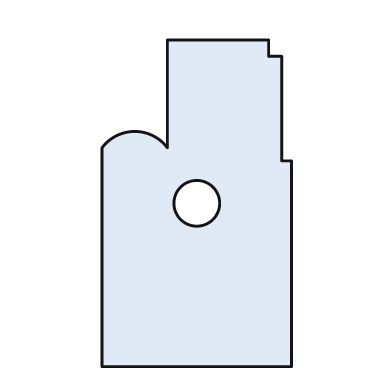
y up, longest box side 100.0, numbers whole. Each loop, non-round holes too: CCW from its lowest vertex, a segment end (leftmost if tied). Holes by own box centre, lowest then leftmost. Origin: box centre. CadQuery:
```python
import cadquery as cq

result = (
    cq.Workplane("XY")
    .moveTo(-29.0, -50.0)
    .lineTo(29.0, -50.0)
    .lineTo(29.0, 13.0)
    .lineTo(26.0, 13.0)
    .lineTo(26.0, 45.0)
    .lineTo(22.0, 45.0)
    .lineTo(22.0, 50.0)
    .lineTo(-9.0, 50.0)
    .lineTo(-9.0, 17.0)
    .threePointArc((-19.0, 22.0), (-29.0, 17.0))
    .close()
    .moveTo(0.0, 0.0)
    .circle(7.0)
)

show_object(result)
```